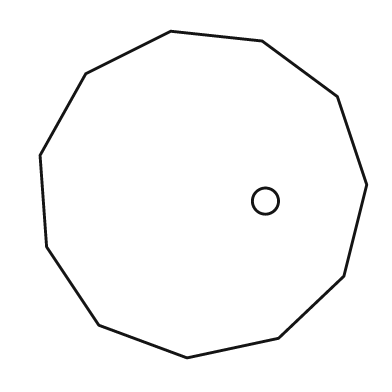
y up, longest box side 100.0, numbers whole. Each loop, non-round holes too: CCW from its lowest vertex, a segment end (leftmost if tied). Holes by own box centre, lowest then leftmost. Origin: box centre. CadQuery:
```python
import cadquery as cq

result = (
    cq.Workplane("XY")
    .moveTo(-5.0, -50.0)
    .lineTo(23.0, -44.0)
    .lineTo(43.0, -25.0)
    .lineTo(50.0, 3.0)
    .lineTo(41.0, 30.0)
    .lineTo(18.0, 47.0)
    .lineTo(-10.0, 50.0)
    .lineTo(-36.0, 37.0)
    .lineTo(-50.0, 12.0)
    .lineTo(-48.0, -16.0)
    .lineTo(-32.0, -40.0)
    .close()
    .moveTo(19.0, -2.0)
    .circle(4.0)
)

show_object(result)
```